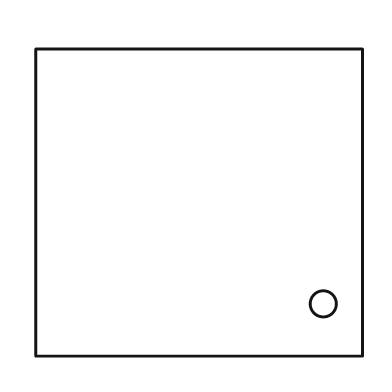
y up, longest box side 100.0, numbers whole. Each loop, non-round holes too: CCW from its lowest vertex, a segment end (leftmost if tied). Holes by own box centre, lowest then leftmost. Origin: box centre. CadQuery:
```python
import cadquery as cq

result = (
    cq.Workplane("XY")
    .moveTo(-50.0, -47.0)
    .lineTo(50.0, -47.0)
    .lineTo(50.0, 47.0)
    .lineTo(-50.0, 47.0)
    .close()
    .moveTo(38.0, -31.0)
    .circle(4.0)
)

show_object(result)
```